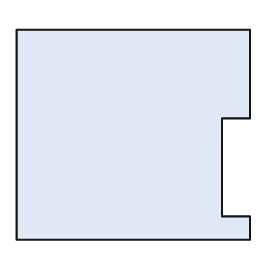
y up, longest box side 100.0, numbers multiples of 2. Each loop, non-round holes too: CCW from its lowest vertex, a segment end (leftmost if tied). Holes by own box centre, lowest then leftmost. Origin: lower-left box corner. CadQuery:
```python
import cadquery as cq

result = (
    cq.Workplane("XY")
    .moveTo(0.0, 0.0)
    .lineTo(100.0, 0.0)
    .lineTo(100.0, 10.0)
    .lineTo(88.0, 10.0)
    .lineTo(88.0, 52.0)
    .lineTo(100.0, 52.0)
    .lineTo(100.0, 90.0)
    .lineTo(0.0, 90.0)
    .close()
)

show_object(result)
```